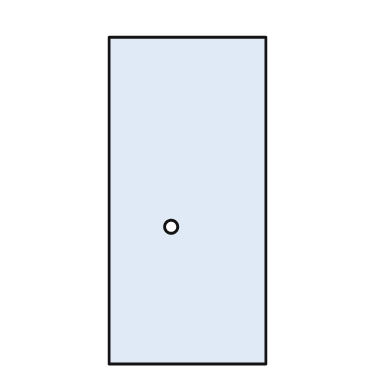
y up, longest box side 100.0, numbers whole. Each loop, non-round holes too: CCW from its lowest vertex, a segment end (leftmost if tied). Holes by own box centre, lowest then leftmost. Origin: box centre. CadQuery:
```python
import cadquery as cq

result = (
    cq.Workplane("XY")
    .moveTo(-24.0, -50.0)
    .lineTo(24.0, -50.0)
    .lineTo(24.0, 50.0)
    .lineTo(-24.0, 50.0)
    .close()
    .moveTo(-5.0, -8.0)
    .circle(2.0)
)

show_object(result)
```